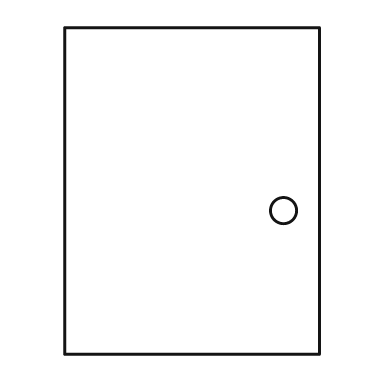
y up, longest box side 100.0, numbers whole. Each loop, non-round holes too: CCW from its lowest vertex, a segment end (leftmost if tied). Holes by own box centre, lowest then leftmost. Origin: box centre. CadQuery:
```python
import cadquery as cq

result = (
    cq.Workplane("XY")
    .moveTo(-39.0, -50.0)
    .lineTo(39.0, -50.0)
    .lineTo(39.0, 50.0)
    .lineTo(-39.0, 50.0)
    .close()
    .moveTo(28.0, -6.0)
    .circle(4.0)
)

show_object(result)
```